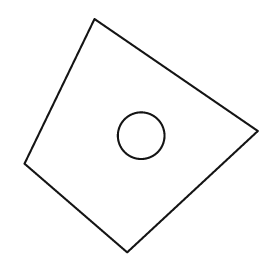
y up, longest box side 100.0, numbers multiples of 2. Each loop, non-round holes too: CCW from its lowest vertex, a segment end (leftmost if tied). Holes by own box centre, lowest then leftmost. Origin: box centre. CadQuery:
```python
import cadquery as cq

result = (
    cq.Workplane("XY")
    .moveTo(-6.0, -50.0)
    .lineTo(50.0, 2.0)
    .lineTo(-20.0, 50.0)
    .lineTo(-50.0, -12.0)
    .close()
    .moveTo(0.0, 0.0)
    .circle(10.0)
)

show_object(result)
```